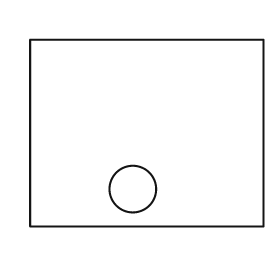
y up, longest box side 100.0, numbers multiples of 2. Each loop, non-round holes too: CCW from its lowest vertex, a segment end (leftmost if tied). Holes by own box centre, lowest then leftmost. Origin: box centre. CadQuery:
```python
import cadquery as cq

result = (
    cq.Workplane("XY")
    .moveTo(-50.0, -40.0)
    .lineTo(50.0, -40.0)
    .lineTo(50.0, 40.0)
    .lineTo(-50.0, 40.0)
    .close()
    .moveTo(-6.0, -24.0)
    .circle(10.0)
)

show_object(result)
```